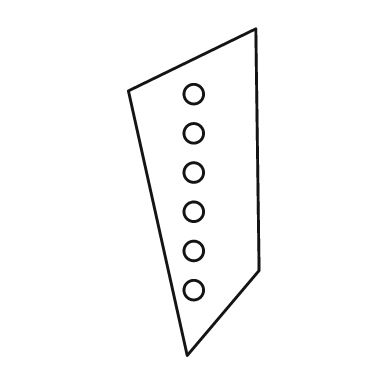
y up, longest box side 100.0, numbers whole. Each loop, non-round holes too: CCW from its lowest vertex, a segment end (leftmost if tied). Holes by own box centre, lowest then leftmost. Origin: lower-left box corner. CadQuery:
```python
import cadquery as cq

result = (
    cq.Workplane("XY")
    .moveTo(18.0, 0.0)
    .lineTo(40.0, 26.0)
    .lineTo(39.0, 100.0)
    .lineTo(0.0, 81.0)
    .close()
    .moveTo(20.0, 20.0)
    .circle(3.0)
    .moveTo(20.0, 32.0)
    .circle(3.0)
    .moveTo(20.0, 44.0)
    .circle(3.0)
    .moveTo(20.0, 56.0)
    .circle(3.0)
    .moveTo(20.0, 68.0)
    .circle(3.0)
    .moveTo(20.0, 80.0)
    .circle(3.0)
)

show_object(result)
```